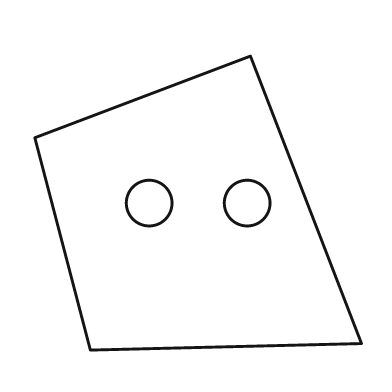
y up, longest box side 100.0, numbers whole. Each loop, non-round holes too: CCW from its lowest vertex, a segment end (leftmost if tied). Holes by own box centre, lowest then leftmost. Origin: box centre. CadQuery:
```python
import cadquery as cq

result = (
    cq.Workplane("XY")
    .moveTo(-33.0, -45.0)
    .lineTo(50.0, -43.0)
    .lineTo(16.0, 45.0)
    .lineTo(-50.0, 20.0)
    .close()
    .moveTo(-15.0, 0.0)
    .circle(7.0)
    .moveTo(15.0, 0.0)
    .circle(7.0)
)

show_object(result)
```